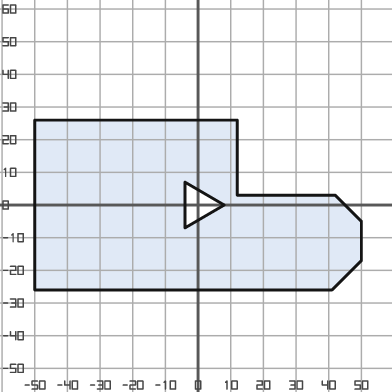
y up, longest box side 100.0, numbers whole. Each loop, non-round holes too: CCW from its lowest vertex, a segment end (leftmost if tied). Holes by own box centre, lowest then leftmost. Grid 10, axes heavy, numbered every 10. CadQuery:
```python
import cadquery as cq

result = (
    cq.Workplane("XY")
    .moveTo(-50.0, -26.0)
    .lineTo(41.0, -26.0)
    .lineTo(50.0, -17.0)
    .lineTo(50.0, -5.0)
    .lineTo(42.0, 3.0)
    .lineTo(12.0, 3.0)
    .lineTo(12.0, 26.0)
    .lineTo(-50.0, 26.0)
    .close()
    .moveTo(-4.0, -7.0)
    .lineTo(8.0, 0.0)
    .lineTo(-4.0, 7.0)
    .close()
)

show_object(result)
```